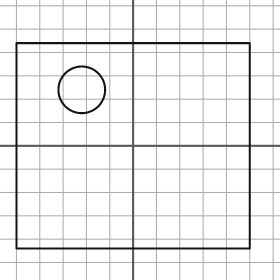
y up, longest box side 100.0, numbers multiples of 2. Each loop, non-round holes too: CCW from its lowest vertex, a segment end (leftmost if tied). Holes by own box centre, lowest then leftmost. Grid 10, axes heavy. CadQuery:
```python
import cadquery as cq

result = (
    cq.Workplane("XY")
    .moveTo(-50.0, -44.0)
    .lineTo(50.0, -44.0)
    .lineTo(50.0, 44.0)
    .lineTo(-50.0, 44.0)
    .close()
    .moveTo(-22.0, 24.0)
    .circle(10.0)
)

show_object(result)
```